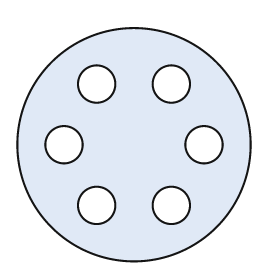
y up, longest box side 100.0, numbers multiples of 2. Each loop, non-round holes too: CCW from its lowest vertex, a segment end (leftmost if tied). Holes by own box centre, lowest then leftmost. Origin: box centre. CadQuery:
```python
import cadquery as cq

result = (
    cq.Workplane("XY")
    .moveTo(0.0, 0.0)
    .circle(50.0)
    .moveTo(-16.0, -26.0)
    .circle(8.0)
    .moveTo(16.0, -26.0)
    .circle(8.0)
    .moveTo(-30.0, 0.0)
    .circle(8.0)
    .moveTo(30.0, 0.0)
    .circle(8.0)
    .moveTo(-16.0, 26.0)
    .circle(8.0)
    .moveTo(16.0, 26.0)
    .circle(8.0)
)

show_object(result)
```